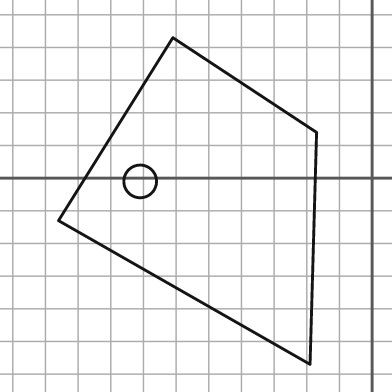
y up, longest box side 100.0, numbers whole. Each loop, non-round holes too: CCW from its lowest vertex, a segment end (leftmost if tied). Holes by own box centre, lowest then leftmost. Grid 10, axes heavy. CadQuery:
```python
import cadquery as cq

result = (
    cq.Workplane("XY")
    .moveTo(-19.0, -57.0)
    .lineTo(-17.0, 14.0)
    .lineTo(-61.0, 43.0)
    .lineTo(-96.0, -13.0)
    .close()
    .moveTo(-71.0, -1.0)
    .circle(5.0)
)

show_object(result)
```